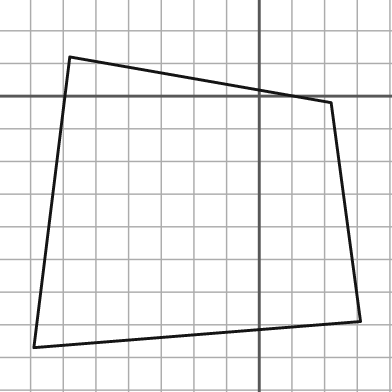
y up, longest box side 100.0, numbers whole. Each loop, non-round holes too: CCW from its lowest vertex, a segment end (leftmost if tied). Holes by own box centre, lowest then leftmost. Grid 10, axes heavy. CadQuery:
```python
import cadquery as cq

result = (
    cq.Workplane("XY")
    .moveTo(-69.0, -77.0)
    .lineTo(31.0, -69.0)
    .lineTo(22.0, -2.0)
    .lineTo(-58.0, 12.0)
    .close()
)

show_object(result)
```